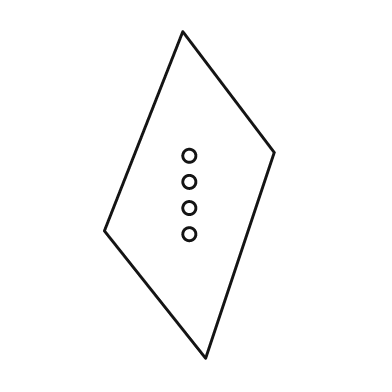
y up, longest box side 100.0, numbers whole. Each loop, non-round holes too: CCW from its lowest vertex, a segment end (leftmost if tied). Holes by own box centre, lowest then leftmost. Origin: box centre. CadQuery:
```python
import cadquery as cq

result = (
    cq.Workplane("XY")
    .moveTo(5.0, -50.0)
    .lineTo(26.0, 13.0)
    .lineTo(-2.0, 50.0)
    .lineTo(-26.0, -11.0)
    .close()
    .moveTo(0.0, -12.0)
    .circle(2.0)
    .moveTo(0.0, -4.0)
    .circle(2.0)
    .moveTo(0.0, 4.0)
    .circle(2.0)
    .moveTo(0.0, 12.0)
    .circle(2.0)
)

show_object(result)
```